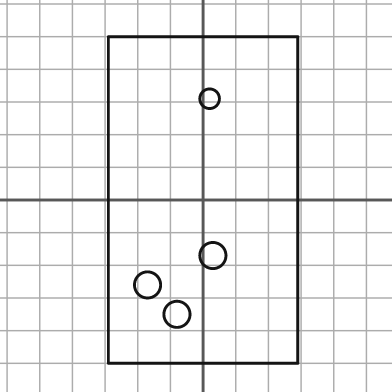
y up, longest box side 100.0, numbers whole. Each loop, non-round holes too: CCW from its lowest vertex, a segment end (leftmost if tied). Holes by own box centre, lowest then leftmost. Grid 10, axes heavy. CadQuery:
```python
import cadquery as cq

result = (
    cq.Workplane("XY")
    .moveTo(-29.0, -50.0)
    .lineTo(29.0, -50.0)
    .lineTo(29.0, 50.0)
    .lineTo(-29.0, 50.0)
    .close()
    .moveTo(-8.0, -35.0)
    .circle(4.0)
    .moveTo(-17.0, -26.0)
    .circle(4.0)
    .moveTo(3.0, -17.0)
    .circle(4.0)
    .moveTo(2.0, 31.0)
    .circle(3.0)
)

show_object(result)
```